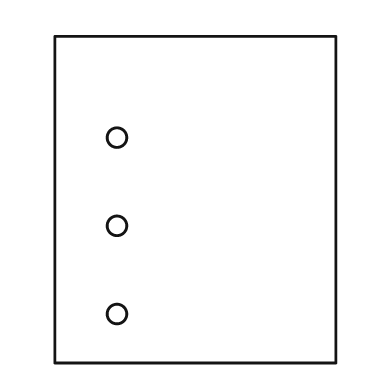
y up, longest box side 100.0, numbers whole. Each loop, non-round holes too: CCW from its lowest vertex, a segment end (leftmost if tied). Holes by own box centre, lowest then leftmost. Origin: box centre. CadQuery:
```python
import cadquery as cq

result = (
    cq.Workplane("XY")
    .moveTo(-43.0, -50.0)
    .lineTo(43.0, -50.0)
    .lineTo(43.0, 50.0)
    .lineTo(-43.0, 50.0)
    .close()
    .moveTo(-24.0, -35.0)
    .circle(3.0)
    .moveTo(-24.0, -8.0)
    .circle(3.0)
    .moveTo(-24.0, 19.0)
    .circle(3.0)
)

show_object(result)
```